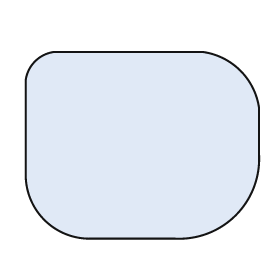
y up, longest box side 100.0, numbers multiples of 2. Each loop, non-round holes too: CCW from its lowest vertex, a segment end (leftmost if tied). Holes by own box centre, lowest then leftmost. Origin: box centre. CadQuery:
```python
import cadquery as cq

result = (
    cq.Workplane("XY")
    .moveTo(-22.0, -40.0)
    .lineTo(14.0, -40.0)
    .threePointArc((40.0, -30.0), (50.0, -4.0))
    .lineTo(50.0, 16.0)
    .threePointArc((42.0, 32.0), (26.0, 40.0))
    .lineTo(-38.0, 40.0)
    .threePointArc((-46.0, 36.0), (-50.0, 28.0))
    .lineTo(-50.0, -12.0)
    .threePointArc((-42.0, -32.0), (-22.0, -40.0))
    .close()
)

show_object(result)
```